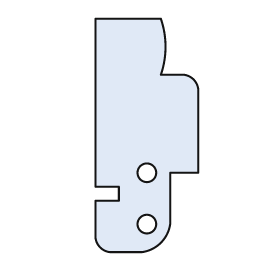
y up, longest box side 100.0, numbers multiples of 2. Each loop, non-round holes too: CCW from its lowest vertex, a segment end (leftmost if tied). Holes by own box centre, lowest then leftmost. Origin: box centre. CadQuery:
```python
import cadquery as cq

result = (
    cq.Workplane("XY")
    .moveTo(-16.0, -50.0)
    .lineTo(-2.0, -50.0)
    .threePointArc((6.0, -46.0), (10.0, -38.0))
    .lineTo(10.0, -16.0)
    .lineTo(22.0, -16.0)
    .lineTo(22.0, 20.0)
    .threePointArc((20.0, 24.0), (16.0, 26.0))
    .lineTo(6.0, 26.0)
    .threePointArc((8.0, 38.0), (6.0, 50.0))
    .lineTo(-22.0, 50.0)
    .lineTo(-22.0, -22.0)
    .lineTo(-12.0, -22.0)
    .lineTo(-12.0, -28.0)
    .lineTo(-22.0, -28.0)
    .lineTo(-22.0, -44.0)
    .threePointArc((-20.0, -48.0), (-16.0, -50.0))
    .close()
    .moveTo(0.0, -38.0)
    .circle(4.0)
    .moveTo(0.0, -16.0)
    .circle(4.0)
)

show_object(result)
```